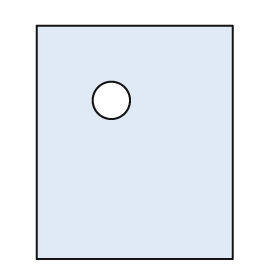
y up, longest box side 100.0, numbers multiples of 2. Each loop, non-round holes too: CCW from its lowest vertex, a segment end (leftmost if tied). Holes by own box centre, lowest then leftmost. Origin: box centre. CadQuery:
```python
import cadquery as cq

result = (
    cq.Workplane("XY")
    .moveTo(-42.0, -50.0)
    .lineTo(42.0, -50.0)
    .lineTo(42.0, 50.0)
    .lineTo(-42.0, 50.0)
    .close()
    .moveTo(-10.0, 18.0)
    .circle(8.0)
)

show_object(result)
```